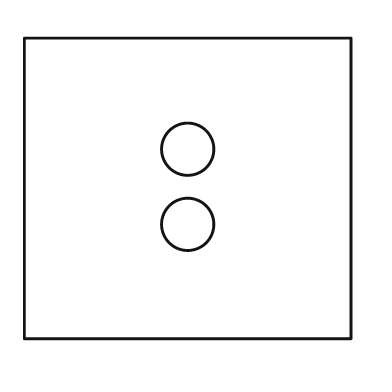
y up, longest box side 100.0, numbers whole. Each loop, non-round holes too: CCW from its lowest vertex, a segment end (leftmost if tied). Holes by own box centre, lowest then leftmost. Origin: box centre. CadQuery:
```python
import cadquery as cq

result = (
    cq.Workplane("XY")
    .moveTo(-50.0, -46.0)
    .lineTo(50.0, -46.0)
    .lineTo(50.0, 46.0)
    .lineTo(-50.0, 46.0)
    .close()
    .moveTo(0.0, -11.0)
    .circle(8.0)
    .moveTo(0.0, 12.0)
    .circle(8.0)
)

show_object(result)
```